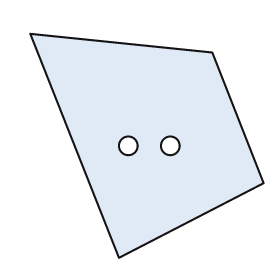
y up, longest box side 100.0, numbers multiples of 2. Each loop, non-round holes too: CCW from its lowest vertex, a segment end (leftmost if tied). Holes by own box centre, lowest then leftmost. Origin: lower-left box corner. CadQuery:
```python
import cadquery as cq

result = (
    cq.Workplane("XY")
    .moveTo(38.0, 0.0)
    .lineTo(100.0, 32.0)
    .lineTo(78.0, 88.0)
    .lineTo(0.0, 96.0)
    .close()
    .moveTo(42.0, 48.0)
    .circle(4.0)
    .moveTo(60.0, 48.0)
    .circle(4.0)
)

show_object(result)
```